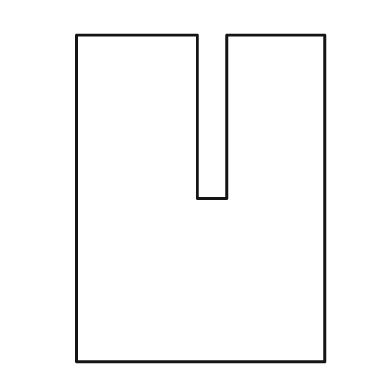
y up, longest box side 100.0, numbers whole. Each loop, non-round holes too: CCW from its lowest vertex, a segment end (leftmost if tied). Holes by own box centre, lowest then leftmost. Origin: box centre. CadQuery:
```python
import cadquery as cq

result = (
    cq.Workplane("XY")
    .moveTo(-38.0, -50.0)
    .lineTo(38.0, -50.0)
    .lineTo(38.0, 50.0)
    .lineTo(8.0, 50.0)
    .lineTo(8.0, 0.0)
    .lineTo(-1.0, 0.0)
    .lineTo(-1.0, 50.0)
    .lineTo(-38.0, 50.0)
    .close()
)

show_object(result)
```